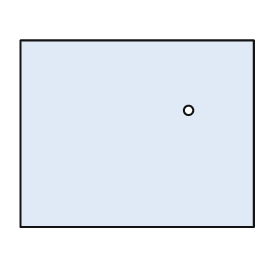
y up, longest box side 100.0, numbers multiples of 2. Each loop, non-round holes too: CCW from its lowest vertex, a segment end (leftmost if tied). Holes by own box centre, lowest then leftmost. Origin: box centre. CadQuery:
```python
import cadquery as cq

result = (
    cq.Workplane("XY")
    .moveTo(-50.0, -40.0)
    .lineTo(50.0, -40.0)
    .lineTo(50.0, 40.0)
    .lineTo(-50.0, 40.0)
    .close()
    .moveTo(22.0, 10.0)
    .circle(2.0)
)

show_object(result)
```